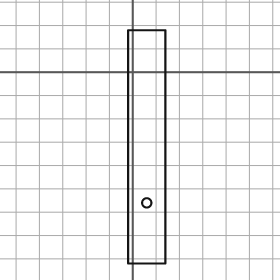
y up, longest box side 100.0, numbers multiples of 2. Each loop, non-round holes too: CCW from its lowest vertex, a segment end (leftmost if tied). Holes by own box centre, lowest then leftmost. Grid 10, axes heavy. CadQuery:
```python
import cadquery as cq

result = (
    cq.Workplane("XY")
    .moveTo(-2.0, -82.0)
    .lineTo(14.0, -82.0)
    .lineTo(14.0, 18.0)
    .lineTo(-2.0, 18.0)
    .close()
    .moveTo(6.0, -56.0)
    .circle(2.0)
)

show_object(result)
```